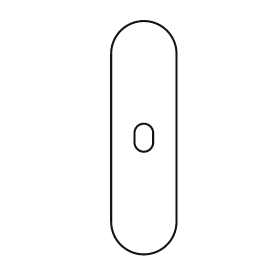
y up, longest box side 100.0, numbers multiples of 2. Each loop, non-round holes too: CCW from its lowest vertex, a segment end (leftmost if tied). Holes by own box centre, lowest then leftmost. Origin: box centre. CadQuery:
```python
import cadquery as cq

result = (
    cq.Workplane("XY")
    .moveTo(-14.0, -36.0)
    .threePointArc((0.0, -50.0), (14.0, -36.0))
    .lineTo(14.0, 36.0)
    .threePointArc((0.0, 50.0), (-14.0, 36.0))
    .close()
    .moveTo(-4.0, -2.0)
    .threePointArc((0.0, -6.0), (4.0, -2.0))
    .lineTo(4.0, 2.0)
    .threePointArc((0.0, 6.0), (-4.0, 2.0))
    .close()
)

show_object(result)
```